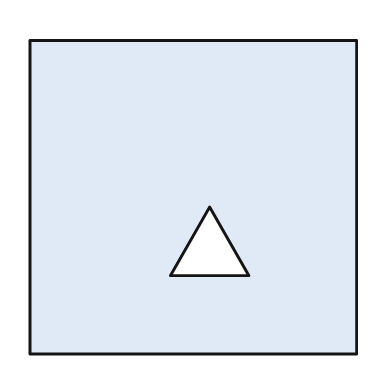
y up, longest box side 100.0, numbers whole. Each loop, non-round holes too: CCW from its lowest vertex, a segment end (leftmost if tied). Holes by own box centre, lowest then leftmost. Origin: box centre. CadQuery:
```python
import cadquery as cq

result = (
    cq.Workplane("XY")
    .moveTo(-50.0, -48.0)
    .lineTo(50.0, -48.0)
    .lineTo(50.0, 48.0)
    .lineTo(-50.0, 48.0)
    .close()
    .moveTo(-7.0, -24.0)
    .lineTo(17.0, -24.0)
    .lineTo(5.0, -3.0)
    .close()
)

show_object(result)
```